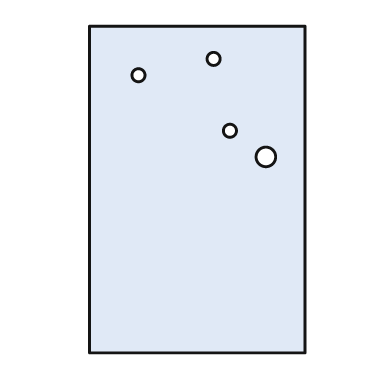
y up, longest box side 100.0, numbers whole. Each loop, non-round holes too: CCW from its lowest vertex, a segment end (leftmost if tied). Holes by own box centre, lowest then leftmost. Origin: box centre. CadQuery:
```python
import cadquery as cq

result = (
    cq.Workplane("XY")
    .moveTo(-33.0, -50.0)
    .lineTo(33.0, -50.0)
    .lineTo(33.0, 50.0)
    .lineTo(-33.0, 50.0)
    .close()
    .moveTo(21.0, 10.0)
    .circle(3.0)
    .moveTo(10.0, 18.0)
    .circle(2.0)
    .moveTo(-18.0, 35.0)
    .circle(2.0)
    .moveTo(5.0, 40.0)
    .circle(2.0)
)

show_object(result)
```